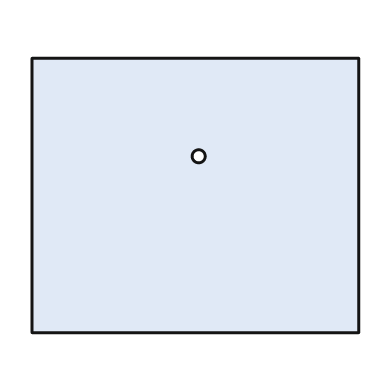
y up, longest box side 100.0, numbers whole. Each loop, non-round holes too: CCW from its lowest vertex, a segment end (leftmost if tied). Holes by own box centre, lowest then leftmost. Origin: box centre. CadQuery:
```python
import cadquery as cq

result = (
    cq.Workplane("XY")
    .moveTo(-50.0, -42.0)
    .lineTo(50.0, -42.0)
    .lineTo(50.0, 42.0)
    .lineTo(-50.0, 42.0)
    .close()
    .moveTo(1.0, 12.0)
    .circle(2.0)
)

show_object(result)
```